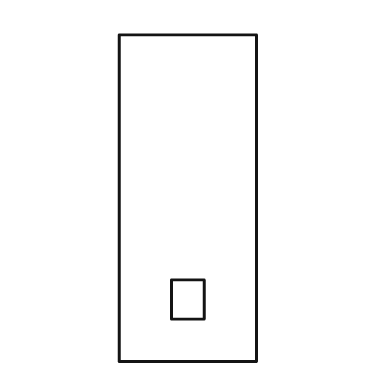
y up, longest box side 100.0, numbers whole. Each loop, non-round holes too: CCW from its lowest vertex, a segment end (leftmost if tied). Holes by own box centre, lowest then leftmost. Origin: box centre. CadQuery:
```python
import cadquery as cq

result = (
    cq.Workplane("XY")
    .moveTo(-21.0, -50.0)
    .lineTo(21.0, -50.0)
    .lineTo(21.0, 50.0)
    .lineTo(-21.0, 50.0)
    .close()
    .moveTo(-5.0, -37.0)
    .lineTo(5.0, -37.0)
    .lineTo(5.0, -25.0)
    .lineTo(-5.0, -25.0)
    .close()
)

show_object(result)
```